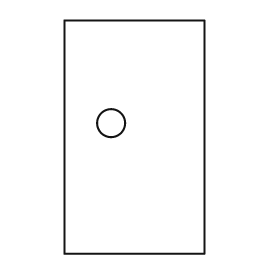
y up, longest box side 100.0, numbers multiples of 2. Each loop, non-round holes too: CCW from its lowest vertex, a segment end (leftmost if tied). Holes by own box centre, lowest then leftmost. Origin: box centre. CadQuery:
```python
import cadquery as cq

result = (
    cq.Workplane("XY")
    .moveTo(-30.0, -50.0)
    .lineTo(30.0, -50.0)
    .lineTo(30.0, 50.0)
    .lineTo(-30.0, 50.0)
    .close()
    .moveTo(-10.0, 6.0)
    .circle(6.0)
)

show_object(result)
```